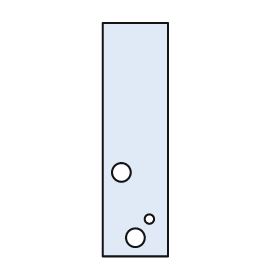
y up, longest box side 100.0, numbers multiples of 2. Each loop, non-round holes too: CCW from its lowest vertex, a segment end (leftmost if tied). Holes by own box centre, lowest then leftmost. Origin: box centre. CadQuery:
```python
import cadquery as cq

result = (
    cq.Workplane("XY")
    .moveTo(-14.0, -50.0)
    .lineTo(14.0, -50.0)
    .lineTo(14.0, 50.0)
    .lineTo(-14.0, 50.0)
    .close()
    .moveTo(0.0, -42.0)
    .circle(4.0)
    .moveTo(6.0, -34.0)
    .circle(2.0)
    .moveTo(-6.0, -14.0)
    .circle(4.0)
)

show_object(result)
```